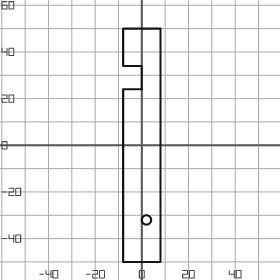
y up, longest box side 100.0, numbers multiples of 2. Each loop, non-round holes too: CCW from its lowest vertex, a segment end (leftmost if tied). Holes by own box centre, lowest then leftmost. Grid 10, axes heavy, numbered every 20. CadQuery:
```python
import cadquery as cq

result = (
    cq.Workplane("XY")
    .moveTo(-8.0, -50.0)
    .lineTo(8.0, -50.0)
    .lineTo(8.0, 50.0)
    .lineTo(-8.0, 50.0)
    .lineTo(-8.0, 34.0)
    .lineTo(0.0, 34.0)
    .lineTo(0.0, 24.0)
    .lineTo(-8.0, 24.0)
    .close()
    .moveTo(2.0, -32.0)
    .circle(2.0)
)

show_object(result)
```